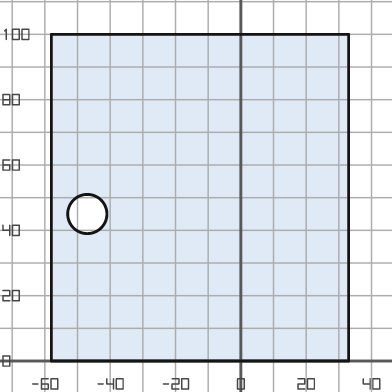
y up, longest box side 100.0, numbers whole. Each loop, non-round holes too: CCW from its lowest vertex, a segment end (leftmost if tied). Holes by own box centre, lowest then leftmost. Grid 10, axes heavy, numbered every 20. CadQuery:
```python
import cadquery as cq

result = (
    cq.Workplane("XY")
    .moveTo(-58.0, 0.0)
    .lineTo(33.0, 0.0)
    .lineTo(33.0, 100.0)
    .lineTo(-58.0, 100.0)
    .close()
    .moveTo(-47.0, 45.0)
    .circle(6.0)
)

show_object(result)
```